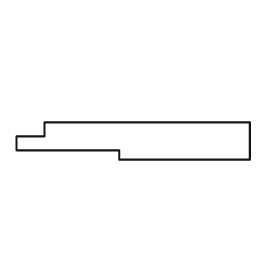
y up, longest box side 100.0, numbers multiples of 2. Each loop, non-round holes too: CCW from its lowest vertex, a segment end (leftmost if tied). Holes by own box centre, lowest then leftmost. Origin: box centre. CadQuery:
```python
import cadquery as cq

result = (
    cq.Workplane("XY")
    .moveTo(-6.0, -8.0)
    .lineTo(50.0, -8.0)
    .lineTo(50.0, 8.0)
    .lineTo(-38.0, 8.0)
    .lineTo(-38.0, 2.0)
    .lineTo(-50.0, 2.0)
    .lineTo(-50.0, -4.0)
    .lineTo(-6.0, -4.0)
    .close()
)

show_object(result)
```